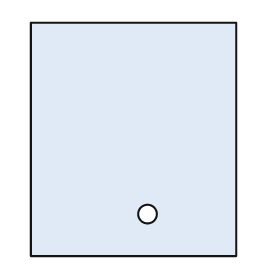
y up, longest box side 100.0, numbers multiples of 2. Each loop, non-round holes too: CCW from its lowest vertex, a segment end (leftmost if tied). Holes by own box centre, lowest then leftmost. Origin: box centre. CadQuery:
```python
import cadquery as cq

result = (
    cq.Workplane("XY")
    .moveTo(-44.0, -50.0)
    .lineTo(44.0, -50.0)
    .lineTo(44.0, 50.0)
    .lineTo(-44.0, 50.0)
    .close()
    .moveTo(6.0, -32.0)
    .circle(4.0)
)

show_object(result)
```